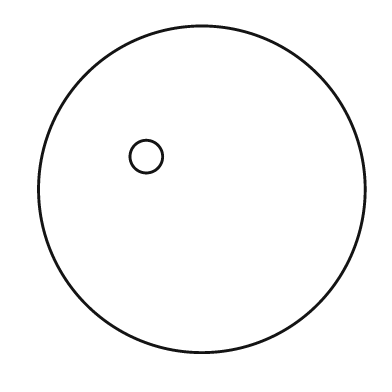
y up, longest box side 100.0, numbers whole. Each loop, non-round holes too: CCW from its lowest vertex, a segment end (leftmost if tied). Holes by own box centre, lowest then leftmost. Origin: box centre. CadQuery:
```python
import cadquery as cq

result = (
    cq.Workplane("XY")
    .moveTo(0.0, 0.0)
    .circle(50.0)
    .moveTo(-17.0, 10.0)
    .circle(5.0)
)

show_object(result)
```